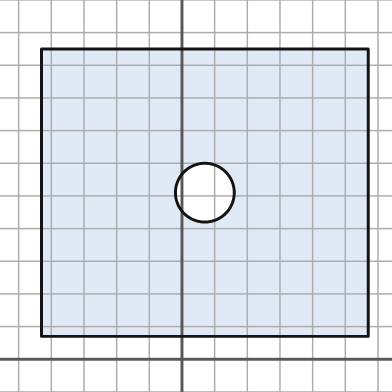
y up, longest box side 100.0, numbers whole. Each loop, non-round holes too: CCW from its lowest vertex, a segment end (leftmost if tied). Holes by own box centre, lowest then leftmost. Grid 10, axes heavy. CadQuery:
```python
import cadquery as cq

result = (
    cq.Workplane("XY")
    .moveTo(-43.0, 7.0)
    .lineTo(57.0, 7.0)
    .lineTo(57.0, 95.0)
    .lineTo(-43.0, 95.0)
    .close()
    .moveTo(7.0, 51.0)
    .circle(9.0)
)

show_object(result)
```